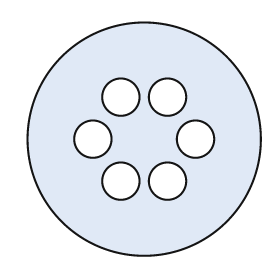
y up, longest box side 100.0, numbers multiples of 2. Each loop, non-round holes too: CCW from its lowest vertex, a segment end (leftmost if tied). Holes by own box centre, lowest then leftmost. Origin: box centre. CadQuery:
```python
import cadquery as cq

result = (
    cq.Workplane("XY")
    .moveTo(0.0, 0.0)
    .circle(50.0)
    .moveTo(-10.0, -18.0)
    .circle(8.0)
    .moveTo(10.0, -18.0)
    .circle(8.0)
    .moveTo(-22.0, 0.0)
    .circle(8.0)
    .moveTo(22.0, 0.0)
    .circle(8.0)
    .moveTo(-10.0, 18.0)
    .circle(8.0)
    .moveTo(10.0, 18.0)
    .circle(8.0)
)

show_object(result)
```